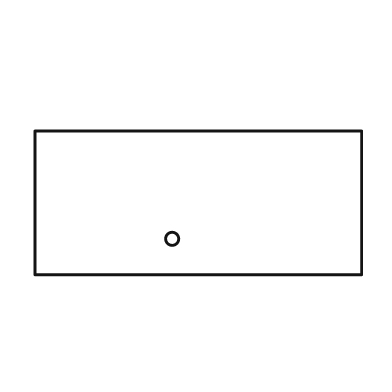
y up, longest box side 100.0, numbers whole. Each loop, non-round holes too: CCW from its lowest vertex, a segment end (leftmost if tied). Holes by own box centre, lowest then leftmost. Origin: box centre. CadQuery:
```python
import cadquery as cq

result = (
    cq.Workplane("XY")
    .moveTo(-50.0, -22.0)
    .lineTo(50.0, -22.0)
    .lineTo(50.0, 22.0)
    .lineTo(-50.0, 22.0)
    .close()
    .moveTo(-8.0, -11.0)
    .circle(2.0)
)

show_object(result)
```